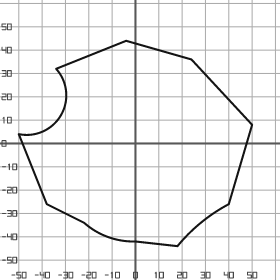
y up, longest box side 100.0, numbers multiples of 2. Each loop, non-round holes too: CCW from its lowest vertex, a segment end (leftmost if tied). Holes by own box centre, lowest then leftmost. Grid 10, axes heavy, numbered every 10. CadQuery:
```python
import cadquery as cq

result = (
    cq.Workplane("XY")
    .moveTo(18.0, -44.0)
    .threePointArc((28.0, -34.0), (40.0, -26.0))
    .lineTo(50.0, 8.0)
    .lineTo(24.0, 36.0)
    .lineTo(-4.0, 44.0)
    .lineTo(-34.0, 32.0)
    .threePointArc((-32.0, 12.0), (-50.0, 4.0))
    .lineTo(-38.0, -26.0)
    .lineTo(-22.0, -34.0)
    .threePointArc((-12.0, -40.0), (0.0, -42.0))
    .close()
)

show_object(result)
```